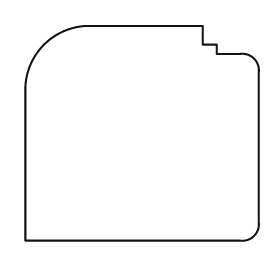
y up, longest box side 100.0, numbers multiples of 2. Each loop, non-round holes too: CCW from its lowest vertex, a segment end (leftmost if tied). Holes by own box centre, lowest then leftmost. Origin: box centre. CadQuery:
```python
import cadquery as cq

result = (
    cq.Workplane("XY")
    .moveTo(-50.0, -46.0)
    .lineTo(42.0, -46.0)
    .threePointArc((48.0, -44.0), (50.0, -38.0))
    .lineTo(50.0, 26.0)
    .threePointArc((48.0, 32.0), (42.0, 34.0))
    .lineTo(32.0, 34.0)
    .lineTo(32.0, 38.0)
    .lineTo(26.0, 38.0)
    .lineTo(26.0, 46.0)
    .lineTo(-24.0, 46.0)
    .threePointArc((-42.0, 38.0), (-50.0, 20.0))
    .close()
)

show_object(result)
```